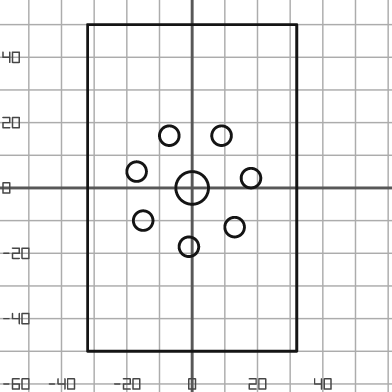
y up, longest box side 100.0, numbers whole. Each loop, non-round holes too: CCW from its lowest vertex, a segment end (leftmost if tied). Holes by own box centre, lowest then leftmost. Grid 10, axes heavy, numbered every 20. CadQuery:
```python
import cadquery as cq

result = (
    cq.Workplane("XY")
    .moveTo(-32.0, -50.0)
    .lineTo(32.0, -50.0)
    .lineTo(32.0, 50.0)
    .lineTo(-32.0, 50.0)
    .close()
    .moveTo(-1.0, -18.0)
    .circle(3.0)
    .moveTo(13.0, -12.0)
    .circle(3.0)
    .moveTo(-15.0, -10.0)
    .circle(3.0)
    .moveTo(0.0, 0.0)
    .circle(5.0)
    .moveTo(18.0, 3.0)
    .circle(3.0)
    .moveTo(-17.0, 5.0)
    .circle(3.0)
    .moveTo(-7.0, 16.0)
    .circle(3.0)
    .moveTo(9.0, 16.0)
    .circle(3.0)
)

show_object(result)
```